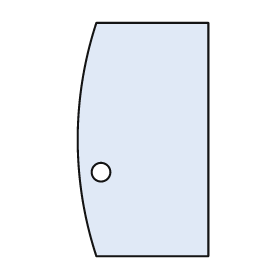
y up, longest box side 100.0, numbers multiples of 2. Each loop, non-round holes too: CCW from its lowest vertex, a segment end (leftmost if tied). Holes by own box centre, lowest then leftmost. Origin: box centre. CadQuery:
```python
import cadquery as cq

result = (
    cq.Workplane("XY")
    .moveTo(-20.0, -50.0)
    .lineTo(28.0, -50.0)
    .lineTo(28.0, 50.0)
    .lineTo(-20.0, 50.0)
    .threePointArc((-28.0, 0.0), (-20.0, -50.0))
    .close()
    .moveTo(-18.0, -14.0)
    .circle(4.0)
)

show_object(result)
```